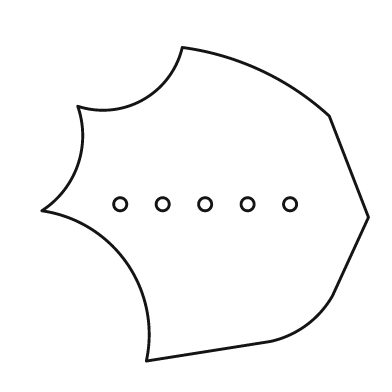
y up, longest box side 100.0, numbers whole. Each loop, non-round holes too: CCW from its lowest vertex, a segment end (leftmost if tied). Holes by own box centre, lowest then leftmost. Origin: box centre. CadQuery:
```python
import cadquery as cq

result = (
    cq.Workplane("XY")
    .moveTo(-18.0, -48.0)
    .lineTo(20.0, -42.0)
    .threePointArc((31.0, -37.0), (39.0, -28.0))
    .lineTo(50.0, -4.0)
    .lineTo(38.0, 27.0)
    .threePointArc((17.0, 41.0), (-7.0, 48.0))
    .threePointArc((-19.0, 32.0), (-39.0, 30.0))
    .threePointArc((-39.0, 12.0), (-50.0, -2.0))
    .threePointArc((-24.0, -18.0), (-18.0, -48.0))
    .close()
    .moveTo(-26.0, 0.0)
    .circle(2.0)
    .moveTo(-13.0, 0.0)
    .circle(2.0)
    .moveTo(0.0, 0.0)
    .circle(2.0)
    .moveTo(13.0, 0.0)
    .circle(2.0)
    .moveTo(26.0, 0.0)
    .circle(2.0)
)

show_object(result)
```